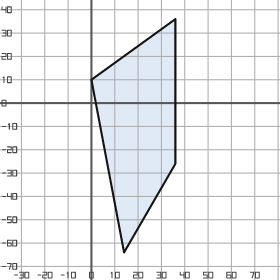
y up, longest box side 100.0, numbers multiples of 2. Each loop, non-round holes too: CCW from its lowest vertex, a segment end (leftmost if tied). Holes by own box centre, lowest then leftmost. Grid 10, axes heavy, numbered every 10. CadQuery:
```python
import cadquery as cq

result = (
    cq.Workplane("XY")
    .moveTo(14.0, -64.0)
    .lineTo(36.0, -26.0)
    .lineTo(36.0, 36.0)
    .lineTo(0.0, 10.0)
    .close()
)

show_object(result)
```